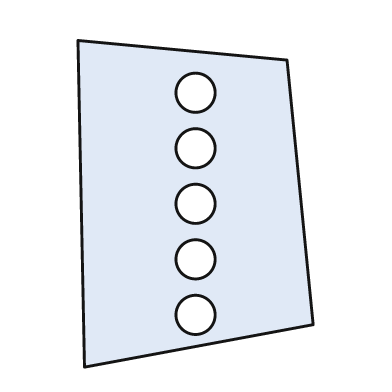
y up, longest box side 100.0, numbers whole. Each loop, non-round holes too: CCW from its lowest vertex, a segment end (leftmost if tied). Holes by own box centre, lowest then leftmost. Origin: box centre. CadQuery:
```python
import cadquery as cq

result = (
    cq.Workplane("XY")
    .moveTo(-34.0, -50.0)
    .lineTo(36.0, -37.0)
    .lineTo(28.0, 44.0)
    .lineTo(-36.0, 50.0)
    .close()
    .moveTo(0.0, -34.0)
    .circle(6.0)
    .moveTo(0.0, -17.0)
    .circle(6.0)
    .moveTo(0.0, 0.0)
    .circle(6.0)
    .moveTo(0.0, 17.0)
    .circle(6.0)
    .moveTo(0.0, 34.0)
    .circle(6.0)
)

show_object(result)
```